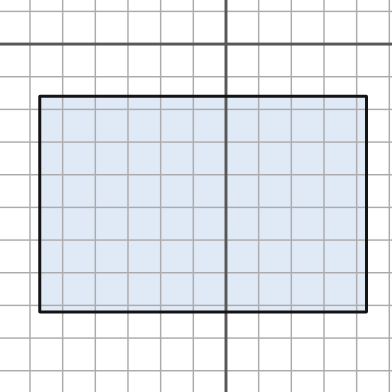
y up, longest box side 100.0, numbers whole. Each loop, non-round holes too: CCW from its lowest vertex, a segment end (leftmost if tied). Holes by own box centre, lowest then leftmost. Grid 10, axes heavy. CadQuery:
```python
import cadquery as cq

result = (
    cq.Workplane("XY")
    .moveTo(-57.0, -82.0)
    .lineTo(43.0, -82.0)
    .lineTo(43.0, -16.0)
    .lineTo(-57.0, -16.0)
    .close()
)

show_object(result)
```